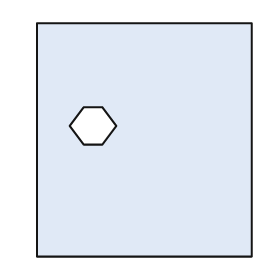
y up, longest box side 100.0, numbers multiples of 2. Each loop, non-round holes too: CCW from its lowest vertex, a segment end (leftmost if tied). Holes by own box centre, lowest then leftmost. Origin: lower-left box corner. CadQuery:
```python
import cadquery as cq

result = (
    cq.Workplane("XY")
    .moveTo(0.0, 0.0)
    .lineTo(92.0, 0.0)
    .lineTo(92.0, 100.0)
    .lineTo(0.0, 100.0)
    .close()
    .moveTo(20.0, 48.0)
    .lineTo(28.0, 48.0)
    .lineTo(34.0, 56.0)
    .lineTo(28.0, 64.0)
    .lineTo(20.0, 64.0)
    .lineTo(14.0, 56.0)
    .close()
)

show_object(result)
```